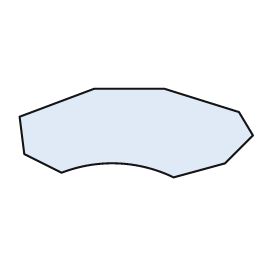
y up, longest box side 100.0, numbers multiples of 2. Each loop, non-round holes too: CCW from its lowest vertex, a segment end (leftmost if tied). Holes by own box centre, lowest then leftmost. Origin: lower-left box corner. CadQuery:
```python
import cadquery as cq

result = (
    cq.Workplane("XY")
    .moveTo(66.0, 0.0)
    .lineTo(88.0, 6.0)
    .lineTo(100.0, 18.0)
    .lineTo(94.0, 28.0)
    .lineTo(62.0, 38.0)
    .lineTo(32.0, 38.0)
    .lineTo(0.0, 26.0)
    .lineTo(2.0, 10.0)
    .lineTo(18.0, 2.0)
    .threePointArc((42.0, 6.0), (66.0, 0.0))
    .close()
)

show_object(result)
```